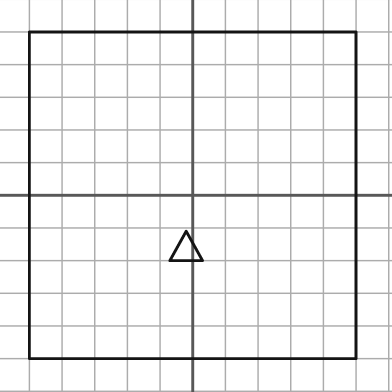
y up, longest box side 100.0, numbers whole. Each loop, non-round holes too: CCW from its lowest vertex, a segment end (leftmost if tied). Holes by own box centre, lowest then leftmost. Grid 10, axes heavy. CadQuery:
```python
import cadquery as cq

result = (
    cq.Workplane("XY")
    .moveTo(-50.0, -50.0)
    .lineTo(50.0, -50.0)
    .lineTo(50.0, 50.0)
    .lineTo(-50.0, 50.0)
    .close()
    .moveTo(-7.0, -20.0)
    .lineTo(3.0, -20.0)
    .lineTo(-2.0, -11.0)
    .close()
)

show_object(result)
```